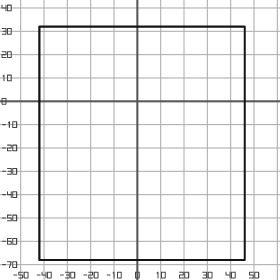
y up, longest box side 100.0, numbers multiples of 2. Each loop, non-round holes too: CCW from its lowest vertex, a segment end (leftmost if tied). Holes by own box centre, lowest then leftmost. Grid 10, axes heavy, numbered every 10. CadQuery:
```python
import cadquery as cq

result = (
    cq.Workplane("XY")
    .moveTo(-42.0, -68.0)
    .lineTo(46.0, -68.0)
    .lineTo(46.0, 32.0)
    .lineTo(-42.0, 32.0)
    .close()
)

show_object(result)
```